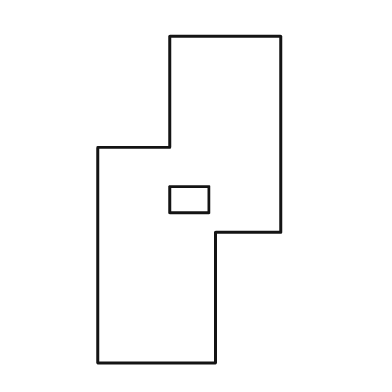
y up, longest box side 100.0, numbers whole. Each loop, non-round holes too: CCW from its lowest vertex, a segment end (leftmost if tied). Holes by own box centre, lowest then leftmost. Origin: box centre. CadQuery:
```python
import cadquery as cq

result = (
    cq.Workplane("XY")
    .moveTo(-28.0, -50.0)
    .lineTo(8.0, -50.0)
    .lineTo(8.0, -10.0)
    .lineTo(28.0, -10.0)
    .lineTo(28.0, 50.0)
    .lineTo(-6.0, 50.0)
    .lineTo(-6.0, 16.0)
    .lineTo(-28.0, 16.0)
    .close()
    .moveTo(-6.0, -4.0)
    .lineTo(6.0, -4.0)
    .lineTo(6.0, 4.0)
    .lineTo(-6.0, 4.0)
    .close()
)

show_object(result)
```